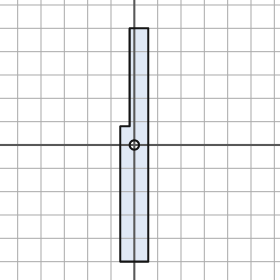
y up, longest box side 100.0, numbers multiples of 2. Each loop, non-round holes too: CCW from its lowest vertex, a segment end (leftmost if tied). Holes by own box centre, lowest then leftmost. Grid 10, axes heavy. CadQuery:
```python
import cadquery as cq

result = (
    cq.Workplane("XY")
    .moveTo(-6.0, -50.0)
    .lineTo(6.0, -50.0)
    .lineTo(6.0, 50.0)
    .lineTo(-2.0, 50.0)
    .lineTo(-2.0, 8.0)
    .lineTo(-6.0, 8.0)
    .close()
    .moveTo(0.0, 0.0)
    .circle(2.0)
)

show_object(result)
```